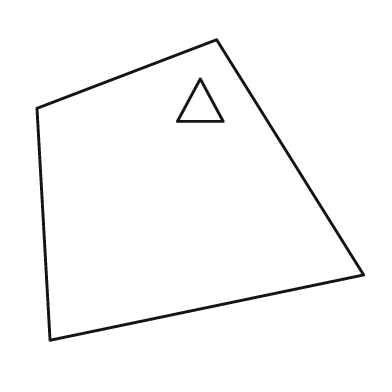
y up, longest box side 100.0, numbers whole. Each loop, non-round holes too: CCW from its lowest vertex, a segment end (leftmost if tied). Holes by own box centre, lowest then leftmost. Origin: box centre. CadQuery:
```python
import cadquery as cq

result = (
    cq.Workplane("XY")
    .moveTo(-46.0, -46.0)
    .lineTo(50.0, -26.0)
    .lineTo(5.0, 46.0)
    .lineTo(-50.0, 25.0)
    .close()
    .moveTo(-7.0, 21.0)
    .lineTo(7.0, 21.0)
    .lineTo(0.0, 34.0)
    .close()
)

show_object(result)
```